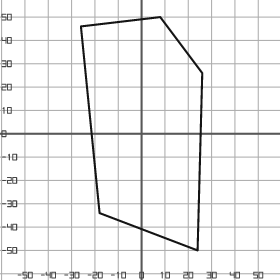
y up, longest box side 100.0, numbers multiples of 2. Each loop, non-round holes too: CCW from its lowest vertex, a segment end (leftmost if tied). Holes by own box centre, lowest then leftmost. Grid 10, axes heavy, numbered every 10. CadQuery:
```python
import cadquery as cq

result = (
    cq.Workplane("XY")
    .moveTo(24.0, -50.0)
    .lineTo(26.0, 26.0)
    .lineTo(8.0, 50.0)
    .lineTo(-26.0, 46.0)
    .lineTo(-18.0, -34.0)
    .close()
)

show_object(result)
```